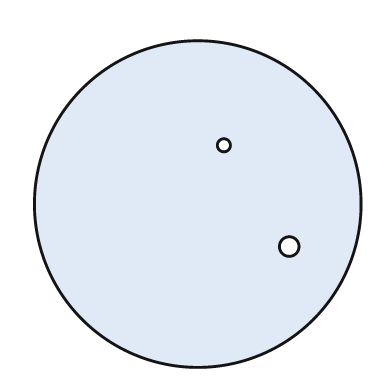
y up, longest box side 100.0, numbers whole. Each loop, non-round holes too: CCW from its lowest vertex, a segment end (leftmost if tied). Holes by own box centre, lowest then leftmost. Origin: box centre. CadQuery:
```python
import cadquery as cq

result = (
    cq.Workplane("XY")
    .moveTo(0.0, 0.0)
    .circle(50.0)
    .moveTo(28.0, -13.0)
    .circle(3.0)
    .moveTo(8.0, 18.0)
    .circle(2.0)
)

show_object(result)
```